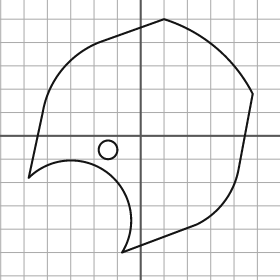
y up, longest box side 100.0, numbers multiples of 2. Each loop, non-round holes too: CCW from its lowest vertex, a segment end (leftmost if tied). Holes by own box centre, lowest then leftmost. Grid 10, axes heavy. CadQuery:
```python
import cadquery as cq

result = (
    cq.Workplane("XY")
    .moveTo(-8.0, -50.0)
    .lineTo(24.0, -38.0)
    .threePointArc((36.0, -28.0), (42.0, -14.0))
    .lineTo(48.0, 18.0)
    .threePointArc((32.0, 38.0), (10.0, 50.0))
    .lineTo(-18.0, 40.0)
    .threePointArc((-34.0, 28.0), (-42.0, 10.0))
    .lineTo(-48.0, -18.0)
    .threePointArc((-14.0, -16.0), (-8.0, -50.0))
    .close()
    .moveTo(-14.0, -6.0)
    .circle(4.0)
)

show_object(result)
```